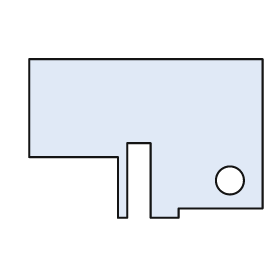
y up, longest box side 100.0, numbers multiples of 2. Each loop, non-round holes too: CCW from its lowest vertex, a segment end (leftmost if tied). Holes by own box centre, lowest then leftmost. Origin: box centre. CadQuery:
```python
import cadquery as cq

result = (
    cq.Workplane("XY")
    .moveTo(-12.0, -34.0)
    .lineTo(-8.0, -34.0)
    .lineTo(-8.0, -2.0)
    .lineTo(2.0, -2.0)
    .lineTo(2.0, -34.0)
    .lineTo(14.0, -34.0)
    .lineTo(14.0, -30.0)
    .lineTo(50.0, -30.0)
    .lineTo(50.0, 34.0)
    .lineTo(-50.0, 34.0)
    .lineTo(-50.0, -8.0)
    .lineTo(-12.0, -8.0)
    .close()
    .moveTo(36.0, -18.0)
    .circle(6.0)
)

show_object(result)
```